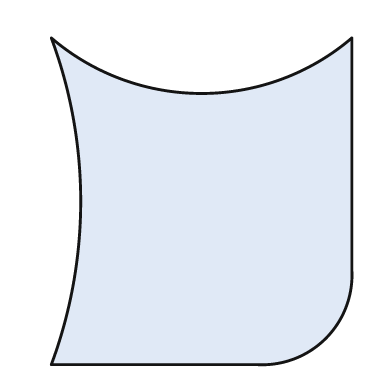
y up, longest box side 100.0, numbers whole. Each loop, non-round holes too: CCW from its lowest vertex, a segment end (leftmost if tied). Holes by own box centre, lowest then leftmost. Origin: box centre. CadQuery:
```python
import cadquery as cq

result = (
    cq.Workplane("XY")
    .moveTo(-46.0, -50.0)
    .lineTo(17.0, -50.0)
    .threePointArc((38.0, -42.0), (46.0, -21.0))
    .lineTo(46.0, 50.0)
    .threePointArc((0.0, 33.0), (-46.0, 50.0))
    .threePointArc((-37.0, 0.0), (-46.0, -50.0))
    .close()
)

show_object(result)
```